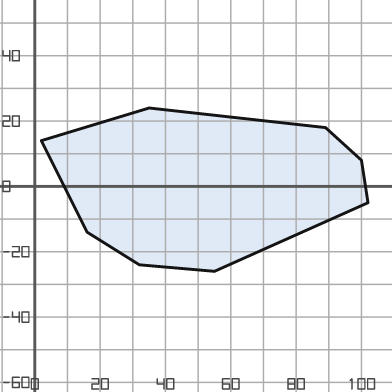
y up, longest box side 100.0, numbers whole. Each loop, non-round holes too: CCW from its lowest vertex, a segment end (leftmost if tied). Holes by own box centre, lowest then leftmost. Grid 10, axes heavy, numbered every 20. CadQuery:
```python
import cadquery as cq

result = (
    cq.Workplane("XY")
    .moveTo(55.0, -26.0)
    .lineTo(102.0, -5.0)
    .lineTo(100.0, 8.0)
    .lineTo(89.0, 18.0)
    .lineTo(35.0, 24.0)
    .lineTo(2.0, 14.0)
    .lineTo(16.0, -14.0)
    .lineTo(32.0, -24.0)
    .close()
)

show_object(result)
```